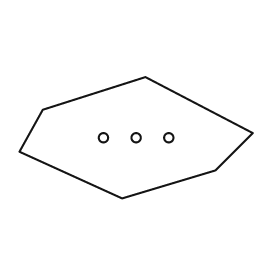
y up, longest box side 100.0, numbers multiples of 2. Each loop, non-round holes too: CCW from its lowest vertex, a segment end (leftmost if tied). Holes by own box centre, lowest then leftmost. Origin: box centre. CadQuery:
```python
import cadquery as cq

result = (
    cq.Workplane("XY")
    .moveTo(-6.0, -26.0)
    .lineTo(34.0, -14.0)
    .lineTo(50.0, 2.0)
    .lineTo(4.0, 26.0)
    .lineTo(-40.0, 12.0)
    .lineTo(-50.0, -6.0)
    .close()
    .moveTo(-14.0, 0.0)
    .circle(2.0)
    .moveTo(0.0, 0.0)
    .circle(2.0)
    .moveTo(14.0, 0.0)
    .circle(2.0)
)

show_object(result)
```